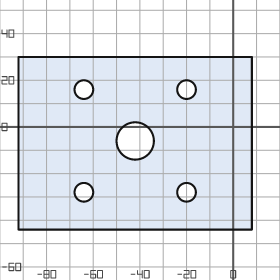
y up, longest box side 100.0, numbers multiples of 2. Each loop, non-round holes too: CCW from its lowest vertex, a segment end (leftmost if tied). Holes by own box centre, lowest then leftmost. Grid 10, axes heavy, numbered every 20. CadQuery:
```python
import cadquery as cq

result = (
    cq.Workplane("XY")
    .moveTo(-92.0, -44.0)
    .lineTo(8.0, -44.0)
    .lineTo(8.0, 30.0)
    .lineTo(-92.0, 30.0)
    .close()
    .moveTo(-64.0, -28.0)
    .circle(4.0)
    .moveTo(-20.0, -28.0)
    .circle(4.0)
    .moveTo(-42.0, -6.0)
    .circle(8.0)
    .moveTo(-64.0, 16.0)
    .circle(4.0)
    .moveTo(-20.0, 16.0)
    .circle(4.0)
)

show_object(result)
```